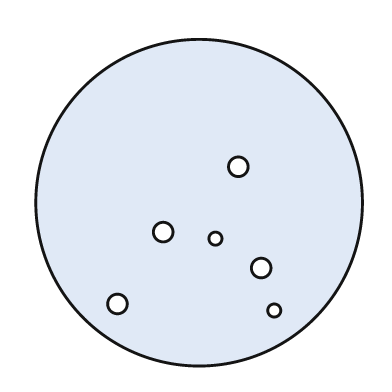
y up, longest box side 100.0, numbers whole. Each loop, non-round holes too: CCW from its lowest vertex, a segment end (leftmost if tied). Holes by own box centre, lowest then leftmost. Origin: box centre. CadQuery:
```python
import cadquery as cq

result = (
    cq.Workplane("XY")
    .moveTo(0.0, 0.0)
    .circle(50.0)
    .moveTo(23.0, -33.0)
    .circle(2.0)
    .moveTo(-25.0, -31.0)
    .circle(3.0)
    .moveTo(19.0, -20.0)
    .circle(3.0)
    .moveTo(5.0, -11.0)
    .circle(2.0)
    .moveTo(-11.0, -9.0)
    .circle(3.0)
    .moveTo(12.0, 11.0)
    .circle(3.0)
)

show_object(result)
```